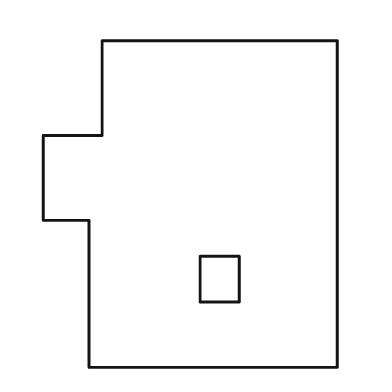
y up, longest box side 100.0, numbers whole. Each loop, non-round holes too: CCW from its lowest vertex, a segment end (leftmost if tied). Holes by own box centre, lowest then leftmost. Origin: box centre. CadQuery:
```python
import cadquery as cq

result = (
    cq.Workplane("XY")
    .moveTo(-31.0, -50.0)
    .lineTo(45.0, -50.0)
    .lineTo(45.0, 50.0)
    .lineTo(-27.0, 50.0)
    .lineTo(-27.0, 21.0)
    .lineTo(-45.0, 21.0)
    .lineTo(-45.0, -5.0)
    .lineTo(-31.0, -5.0)
    .close()
    .moveTo(3.0, -30.0)
    .lineTo(15.0, -30.0)
    .lineTo(15.0, -16.0)
    .lineTo(3.0, -16.0)
    .close()
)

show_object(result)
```